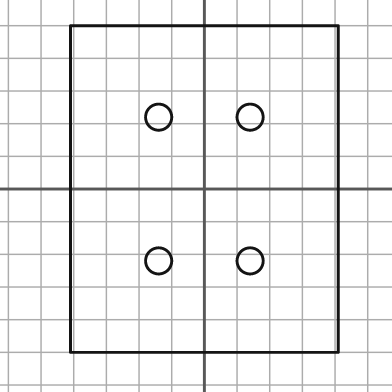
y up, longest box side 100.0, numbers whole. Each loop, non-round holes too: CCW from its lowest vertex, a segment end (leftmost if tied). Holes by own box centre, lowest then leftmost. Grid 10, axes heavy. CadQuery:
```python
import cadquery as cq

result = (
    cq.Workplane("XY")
    .moveTo(-41.0, -50.0)
    .lineTo(41.0, -50.0)
    .lineTo(41.0, 50.0)
    .lineTo(-41.0, 50.0)
    .close()
    .moveTo(-14.0, -22.0)
    .circle(4.0)
    .moveTo(14.0, -22.0)
    .circle(4.0)
    .moveTo(-14.0, 22.0)
    .circle(4.0)
    .moveTo(14.0, 22.0)
    .circle(4.0)
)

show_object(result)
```